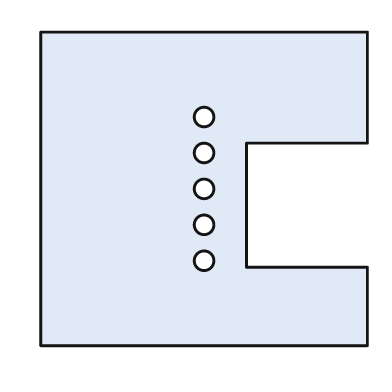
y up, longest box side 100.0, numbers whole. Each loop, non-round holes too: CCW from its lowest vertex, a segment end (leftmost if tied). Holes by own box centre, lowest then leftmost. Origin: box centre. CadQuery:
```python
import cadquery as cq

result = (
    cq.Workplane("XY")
    .moveTo(-50.0, -48.0)
    .lineTo(50.0, -48.0)
    .lineTo(50.0, -24.0)
    .lineTo(13.0, -24.0)
    .lineTo(13.0, 14.0)
    .lineTo(50.0, 14.0)
    .lineTo(50.0, 48.0)
    .lineTo(-50.0, 48.0)
    .close()
    .moveTo(0.0, -22.0)
    .circle(3.0)
    .moveTo(0.0, -11.0)
    .circle(3.0)
    .moveTo(0.0, 0.0)
    .circle(3.0)
    .moveTo(0.0, 11.0)
    .circle(3.0)
    .moveTo(0.0, 22.0)
    .circle(3.0)
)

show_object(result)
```